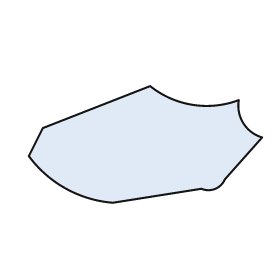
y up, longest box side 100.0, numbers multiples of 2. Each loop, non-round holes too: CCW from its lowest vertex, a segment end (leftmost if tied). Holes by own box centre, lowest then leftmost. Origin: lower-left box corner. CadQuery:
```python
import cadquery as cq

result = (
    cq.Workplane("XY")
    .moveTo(36.0, 0.0)
    .lineTo(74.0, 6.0)
    .threePointArc((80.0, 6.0), (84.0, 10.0))
    .lineTo(100.0, 28.0)
    .threePointArc((92.0, 34.0), (90.0, 44.0))
    .threePointArc((70.0, 42.0), (52.0, 50.0))
    .lineTo(6.0, 32.0)
    .lineTo(0.0, 20.0)
    .threePointArc((16.0, 6.0), (36.0, 0.0))
    .close()
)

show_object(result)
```